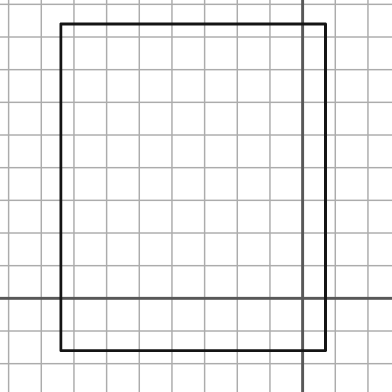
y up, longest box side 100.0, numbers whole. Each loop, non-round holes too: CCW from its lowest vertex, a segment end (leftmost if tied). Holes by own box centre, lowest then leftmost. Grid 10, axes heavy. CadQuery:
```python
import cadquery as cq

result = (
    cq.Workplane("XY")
    .moveTo(-74.0, -16.0)
    .lineTo(7.0, -16.0)
    .lineTo(7.0, 84.0)
    .lineTo(-74.0, 84.0)
    .close()
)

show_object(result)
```